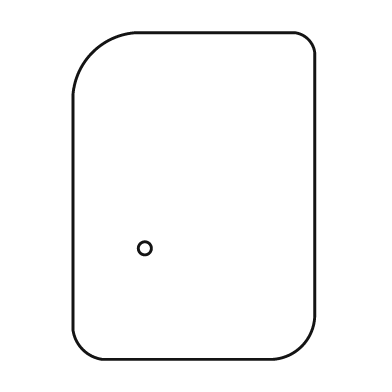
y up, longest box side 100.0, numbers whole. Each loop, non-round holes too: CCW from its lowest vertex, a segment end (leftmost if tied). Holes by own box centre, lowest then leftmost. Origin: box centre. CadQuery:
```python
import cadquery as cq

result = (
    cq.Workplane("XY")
    .moveTo(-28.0, -50.0)
    .lineTo(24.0, -50.0)
    .threePointArc((33.0, -46.0), (37.0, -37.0))
    .lineTo(37.0, 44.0)
    .threePointArc((35.0, 48.0), (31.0, 50.0))
    .lineTo(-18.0, 50.0)
    .threePointArc((-31.0, 44.0), (-37.0, 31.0))
    .lineTo(-37.0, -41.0)
    .threePointArc((-34.0, -47.0), (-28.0, -50.0))
    .close()
    .moveTo(-15.0, -16.0)
    .circle(2.0)
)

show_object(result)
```